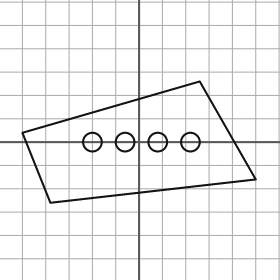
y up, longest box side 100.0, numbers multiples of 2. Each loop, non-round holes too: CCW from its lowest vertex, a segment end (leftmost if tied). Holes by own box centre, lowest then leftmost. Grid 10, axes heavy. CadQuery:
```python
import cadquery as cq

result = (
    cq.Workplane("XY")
    .moveTo(-38.0, -26.0)
    .lineTo(50.0, -16.0)
    .lineTo(26.0, 26.0)
    .lineTo(-50.0, 4.0)
    .close()
    .moveTo(-20.0, 0.0)
    .circle(4.0)
    .moveTo(-6.0, 0.0)
    .circle(4.0)
    .moveTo(8.0, 0.0)
    .circle(4.0)
    .moveTo(22.0, 0.0)
    .circle(4.0)
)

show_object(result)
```